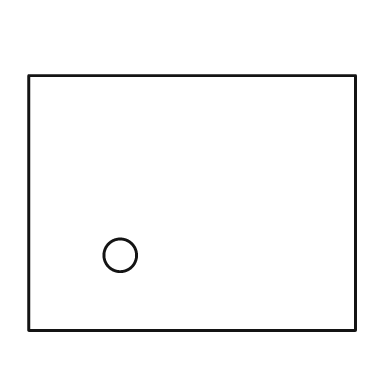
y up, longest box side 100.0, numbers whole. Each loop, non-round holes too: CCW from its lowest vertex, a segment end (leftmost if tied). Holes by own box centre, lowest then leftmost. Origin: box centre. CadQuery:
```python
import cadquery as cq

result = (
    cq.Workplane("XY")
    .moveTo(-50.0, -39.0)
    .lineTo(50.0, -39.0)
    .lineTo(50.0, 39.0)
    .lineTo(-50.0, 39.0)
    .close()
    .moveTo(-22.0, -16.0)
    .circle(5.0)
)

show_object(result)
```